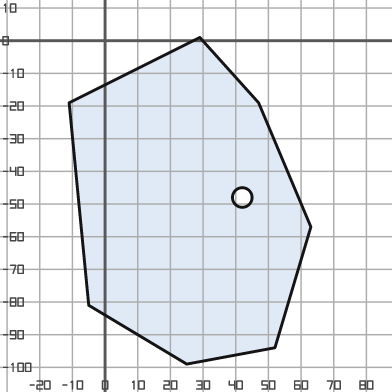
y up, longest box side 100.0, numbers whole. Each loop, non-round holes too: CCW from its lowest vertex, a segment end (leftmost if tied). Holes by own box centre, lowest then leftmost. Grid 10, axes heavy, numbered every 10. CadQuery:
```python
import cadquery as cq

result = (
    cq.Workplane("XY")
    .moveTo(25.0, -99.0)
    .lineTo(52.0, -94.0)
    .lineTo(63.0, -57.0)
    .lineTo(47.0, -19.0)
    .lineTo(29.0, 1.0)
    .lineTo(-11.0, -19.0)
    .lineTo(-5.0, -81.0)
    .close()
    .moveTo(42.0, -48.0)
    .circle(3.0)
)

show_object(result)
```